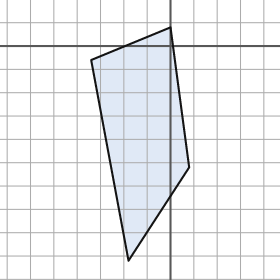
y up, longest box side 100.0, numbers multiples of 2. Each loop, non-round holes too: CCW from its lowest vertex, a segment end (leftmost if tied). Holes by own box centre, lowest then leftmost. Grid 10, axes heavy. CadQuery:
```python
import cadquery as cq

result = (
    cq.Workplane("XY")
    .moveTo(-18.0, -92.0)
    .lineTo(8.0, -52.0)
    .lineTo(0.0, 8.0)
    .lineTo(-34.0, -6.0)
    .close()
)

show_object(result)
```